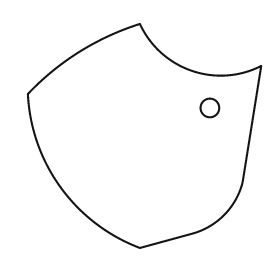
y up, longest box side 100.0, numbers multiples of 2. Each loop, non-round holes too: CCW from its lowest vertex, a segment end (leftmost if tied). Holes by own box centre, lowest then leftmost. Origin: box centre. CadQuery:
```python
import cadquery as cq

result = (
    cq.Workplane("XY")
    .moveTo(-2.0, -48.0)
    .lineTo(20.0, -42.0)
    .threePointArc((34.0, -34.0), (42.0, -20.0))
    .lineTo(50.0, 30.0)
    .threePointArc((20.0, 28.0), (-2.0, 48.0))
    .threePointArc((-28.0, 36.0), (-50.0, 18.0))
    .threePointArc((-36.0, -22.0), (-2.0, -48.0))
    .close()
    .moveTo(28.0, 12.0)
    .circle(4.0)
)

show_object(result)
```